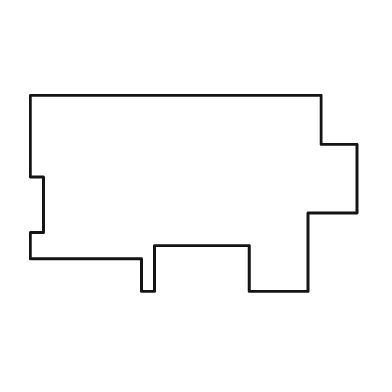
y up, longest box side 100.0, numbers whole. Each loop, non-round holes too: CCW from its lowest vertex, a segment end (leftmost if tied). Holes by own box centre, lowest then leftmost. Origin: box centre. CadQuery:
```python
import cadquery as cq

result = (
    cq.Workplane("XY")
    .moveTo(-16.0, -30.0)
    .lineTo(-12.0, -30.0)
    .lineTo(-12.0, -16.0)
    .lineTo(17.0, -16.0)
    .lineTo(17.0, -30.0)
    .lineTo(35.0, -30.0)
    .lineTo(35.0, -6.0)
    .lineTo(50.0, -6.0)
    .lineTo(50.0, 15.0)
    .lineTo(39.0, 15.0)
    .lineTo(39.0, 30.0)
    .lineTo(-50.0, 30.0)
    .lineTo(-50.0, 5.0)
    .lineTo(-46.0, 5.0)
    .lineTo(-46.0, -12.0)
    .lineTo(-50.0, -12.0)
    .lineTo(-50.0, -20.0)
    .lineTo(-16.0, -20.0)
    .close()
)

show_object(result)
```